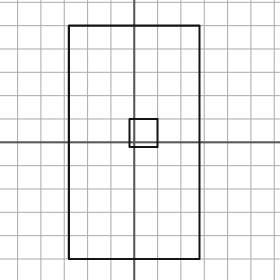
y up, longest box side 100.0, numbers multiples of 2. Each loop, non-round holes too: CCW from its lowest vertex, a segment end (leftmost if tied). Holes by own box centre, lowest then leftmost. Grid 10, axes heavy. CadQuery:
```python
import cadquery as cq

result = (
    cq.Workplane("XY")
    .moveTo(-28.0, -50.0)
    .lineTo(28.0, -50.0)
    .lineTo(28.0, 50.0)
    .lineTo(-28.0, 50.0)
    .close()
    .moveTo(-2.0, -2.0)
    .lineTo(10.0, -2.0)
    .lineTo(10.0, 10.0)
    .lineTo(-2.0, 10.0)
    .close()
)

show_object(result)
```